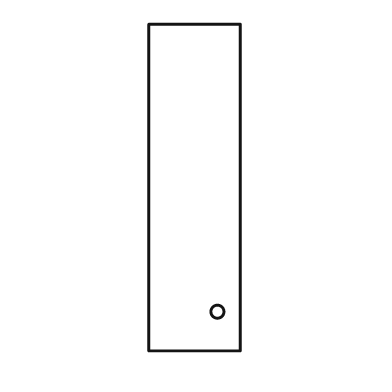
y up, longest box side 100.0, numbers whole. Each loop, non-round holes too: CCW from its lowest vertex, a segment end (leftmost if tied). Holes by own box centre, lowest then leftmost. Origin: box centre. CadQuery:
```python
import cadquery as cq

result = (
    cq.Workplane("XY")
    .moveTo(-14.0, -50.0)
    .lineTo(14.0, -50.0)
    .lineTo(14.0, 50.0)
    .lineTo(-14.0, 50.0)
    .close()
    .moveTo(7.0, -38.0)
    .circle(2.0)
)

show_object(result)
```